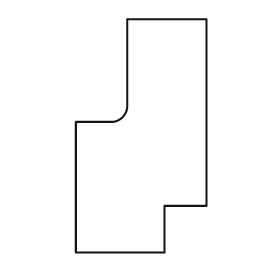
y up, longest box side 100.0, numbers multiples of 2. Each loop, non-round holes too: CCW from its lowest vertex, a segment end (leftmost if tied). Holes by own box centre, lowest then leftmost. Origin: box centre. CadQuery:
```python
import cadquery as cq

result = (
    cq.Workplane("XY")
    .moveTo(-28.0, -50.0)
    .lineTo(10.0, -50.0)
    .lineTo(10.0, -30.0)
    .lineTo(28.0, -30.0)
    .lineTo(28.0, 50.0)
    .lineTo(-6.0, 50.0)
    .lineTo(-6.0, 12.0)
    .threePointArc((-8.0, 8.0), (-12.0, 6.0))
    .lineTo(-28.0, 6.0)
    .close()
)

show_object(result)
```